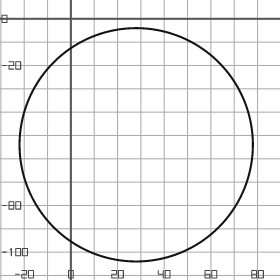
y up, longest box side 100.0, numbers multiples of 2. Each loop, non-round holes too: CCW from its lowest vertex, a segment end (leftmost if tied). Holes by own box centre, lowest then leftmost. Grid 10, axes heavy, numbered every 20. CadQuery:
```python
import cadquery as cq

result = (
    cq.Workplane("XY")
    .moveTo(28.0, -54.0)
    .circle(50.0)
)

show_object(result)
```